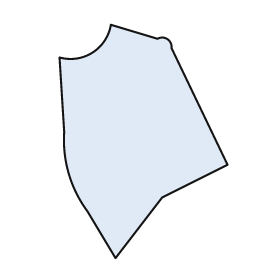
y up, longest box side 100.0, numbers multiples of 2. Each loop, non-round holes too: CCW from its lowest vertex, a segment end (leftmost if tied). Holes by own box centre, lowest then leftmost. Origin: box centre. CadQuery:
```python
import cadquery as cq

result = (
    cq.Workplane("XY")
    .moveTo(-12.0, -50.0)
    .lineTo(8.0, -24.0)
    .lineTo(36.0, -10.0)
    .lineTo(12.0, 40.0)
    .threePointArc((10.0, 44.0), (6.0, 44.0))
    .lineTo(-14.0, 50.0)
    .threePointArc((-22.0, 38.0), (-36.0, 36.0))
    .lineTo(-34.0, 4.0)
    .threePointArc((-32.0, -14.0), (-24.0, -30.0))
    .close()
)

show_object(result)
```